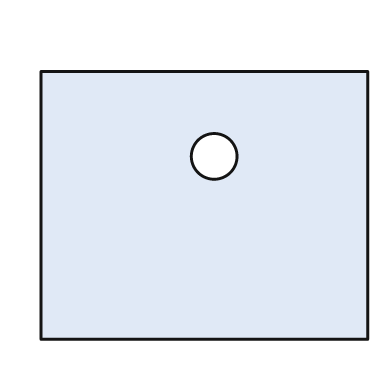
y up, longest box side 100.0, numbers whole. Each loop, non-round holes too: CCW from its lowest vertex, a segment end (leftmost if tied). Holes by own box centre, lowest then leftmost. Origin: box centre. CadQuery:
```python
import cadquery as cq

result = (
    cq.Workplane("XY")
    .moveTo(-50.0, -41.0)
    .lineTo(50.0, -41.0)
    .lineTo(50.0, 41.0)
    .lineTo(-50.0, 41.0)
    .close()
    .moveTo(3.0, 15.0)
    .circle(7.0)
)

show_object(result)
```